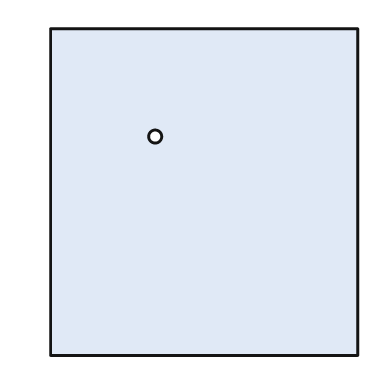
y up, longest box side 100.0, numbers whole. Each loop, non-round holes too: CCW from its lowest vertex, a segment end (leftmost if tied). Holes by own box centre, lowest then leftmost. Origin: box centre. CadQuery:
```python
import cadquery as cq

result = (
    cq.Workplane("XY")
    .moveTo(-47.0, -50.0)
    .lineTo(47.0, -50.0)
    .lineTo(47.0, 50.0)
    .lineTo(-47.0, 50.0)
    .close()
    .moveTo(-15.0, 17.0)
    .circle(2.0)
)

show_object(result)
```